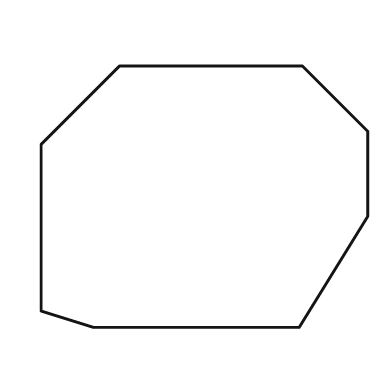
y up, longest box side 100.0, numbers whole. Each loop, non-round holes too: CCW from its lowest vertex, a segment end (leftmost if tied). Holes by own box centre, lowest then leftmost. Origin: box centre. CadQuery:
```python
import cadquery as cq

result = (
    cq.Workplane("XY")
    .moveTo(-34.0, -40.0)
    .lineTo(29.0, -40.0)
    .lineTo(50.0, -6.0)
    .lineTo(50.0, 20.0)
    .lineTo(30.0, 40.0)
    .lineTo(-26.0, 40.0)
    .lineTo(-50.0, 16.0)
    .lineTo(-50.0, -35.0)
    .close()
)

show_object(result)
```